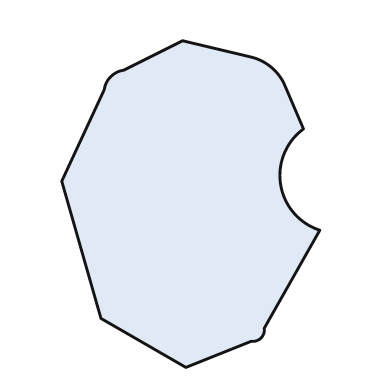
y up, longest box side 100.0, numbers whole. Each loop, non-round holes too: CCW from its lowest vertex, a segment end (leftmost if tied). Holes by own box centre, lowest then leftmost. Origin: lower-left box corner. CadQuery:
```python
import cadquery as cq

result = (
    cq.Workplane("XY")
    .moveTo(38.0, 0.0)
    .lineTo(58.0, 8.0)
    .threePointArc((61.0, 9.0), (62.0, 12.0))
    .lineTo(79.0, 42.0)
    .threePointArc((67.0, 56.0), (74.0, 73.0))
    .lineTo(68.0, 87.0)
    .threePointArc((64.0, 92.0), (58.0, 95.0))
    .lineTo(37.0, 100.0)
    .lineTo(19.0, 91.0)
    .threePointArc((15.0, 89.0), (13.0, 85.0))
    .lineTo(0.0, 57.0)
    .lineTo(12.0, 15.0)
    .close()
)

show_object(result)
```